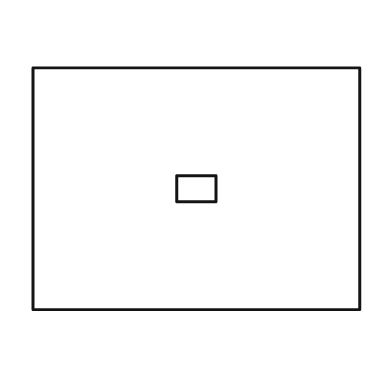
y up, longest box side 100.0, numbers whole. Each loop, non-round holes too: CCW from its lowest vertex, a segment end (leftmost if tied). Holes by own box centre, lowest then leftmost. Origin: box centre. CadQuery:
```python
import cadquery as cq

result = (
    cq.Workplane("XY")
    .moveTo(-50.0, -37.0)
    .lineTo(50.0, -37.0)
    .lineTo(50.0, 37.0)
    .lineTo(-50.0, 37.0)
    .close()
    .moveTo(-6.0, -4.0)
    .lineTo(6.0, -4.0)
    .lineTo(6.0, 4.0)
    .lineTo(-6.0, 4.0)
    .close()
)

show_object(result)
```